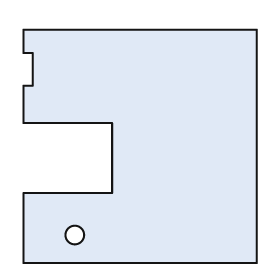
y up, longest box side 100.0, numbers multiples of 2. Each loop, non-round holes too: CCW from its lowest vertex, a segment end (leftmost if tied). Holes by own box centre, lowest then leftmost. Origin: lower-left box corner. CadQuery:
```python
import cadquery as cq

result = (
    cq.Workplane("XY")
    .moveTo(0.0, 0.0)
    .lineTo(100.0, 0.0)
    .lineTo(100.0, 100.0)
    .lineTo(0.0, 100.0)
    .lineTo(0.0, 90.0)
    .lineTo(4.0, 90.0)
    .lineTo(4.0, 76.0)
    .lineTo(0.0, 76.0)
    .lineTo(0.0, 60.0)
    .lineTo(38.0, 60.0)
    .lineTo(38.0, 30.0)
    .lineTo(0.0, 30.0)
    .close()
    .moveTo(22.0, 12.0)
    .circle(4.0)
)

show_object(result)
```